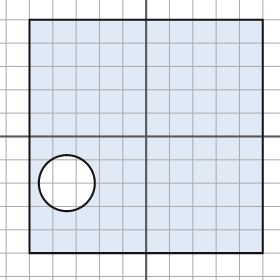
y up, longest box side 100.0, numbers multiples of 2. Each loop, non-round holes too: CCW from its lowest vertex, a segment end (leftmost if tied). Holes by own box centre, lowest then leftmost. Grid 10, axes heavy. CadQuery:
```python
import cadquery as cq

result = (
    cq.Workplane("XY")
    .moveTo(-50.0, -50.0)
    .lineTo(50.0, -50.0)
    .lineTo(50.0, 50.0)
    .lineTo(-50.0, 50.0)
    .close()
    .moveTo(-34.0, -20.0)
    .circle(12.0)
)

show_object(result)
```